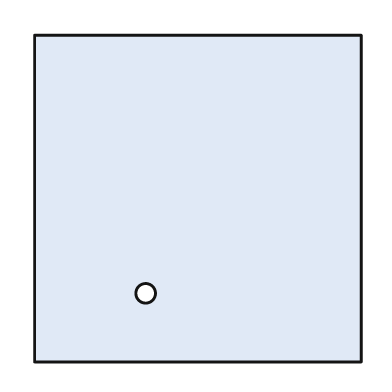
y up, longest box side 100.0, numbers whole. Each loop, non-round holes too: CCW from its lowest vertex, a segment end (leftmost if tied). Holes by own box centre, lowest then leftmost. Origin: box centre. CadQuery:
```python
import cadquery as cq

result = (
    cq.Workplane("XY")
    .moveTo(-50.0, -50.0)
    .lineTo(50.0, -50.0)
    .lineTo(50.0, 50.0)
    .lineTo(-50.0, 50.0)
    .close()
    .moveTo(-16.0, -29.0)
    .circle(3.0)
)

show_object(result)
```